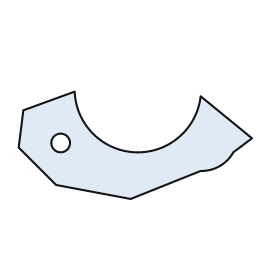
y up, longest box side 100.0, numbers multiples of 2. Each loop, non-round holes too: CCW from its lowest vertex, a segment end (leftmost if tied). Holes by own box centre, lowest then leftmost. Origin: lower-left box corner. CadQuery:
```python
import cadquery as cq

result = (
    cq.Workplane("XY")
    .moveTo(48.0, 0.0)
    .lineTo(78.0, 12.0)
    .threePointArc((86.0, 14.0), (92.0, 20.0))
    .lineTo(100.0, 26.0)
    .lineTo(78.0, 44.0)
    .threePointArc((50.0, 20.0), (24.0, 46.0))
    .lineTo(2.0, 38.0)
    .lineTo(0.0, 22.0)
    .lineTo(16.0, 6.0)
    .close()
    .moveTo(18.0, 24.0)
    .circle(4.0)
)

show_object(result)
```